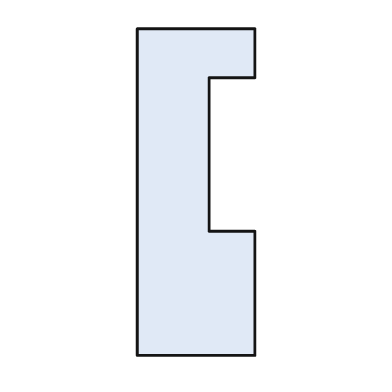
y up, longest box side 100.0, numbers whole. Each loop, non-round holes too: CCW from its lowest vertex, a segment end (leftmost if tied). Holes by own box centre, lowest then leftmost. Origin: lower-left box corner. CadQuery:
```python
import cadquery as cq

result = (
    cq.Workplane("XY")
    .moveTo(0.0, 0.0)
    .lineTo(36.0, 0.0)
    .lineTo(36.0, 38.0)
    .lineTo(22.0, 38.0)
    .lineTo(22.0, 85.0)
    .lineTo(36.0, 85.0)
    .lineTo(36.0, 100.0)
    .lineTo(0.0, 100.0)
    .close()
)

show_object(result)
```